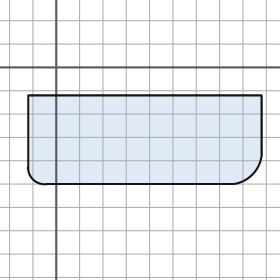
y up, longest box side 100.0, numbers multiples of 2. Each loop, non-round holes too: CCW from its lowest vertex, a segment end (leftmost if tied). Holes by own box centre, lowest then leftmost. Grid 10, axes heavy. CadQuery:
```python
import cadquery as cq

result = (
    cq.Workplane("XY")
    .moveTo(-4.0, -50.0)
    .lineTo(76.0, -50.0)
    .threePointArc((84.0, -46.0), (88.0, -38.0))
    .lineTo(88.0, -12.0)
    .lineTo(-12.0, -12.0)
    .lineTo(-12.0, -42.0)
    .threePointArc((-10.0, -48.0), (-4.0, -50.0))
    .close()
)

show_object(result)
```